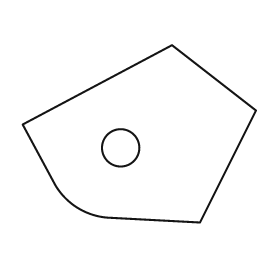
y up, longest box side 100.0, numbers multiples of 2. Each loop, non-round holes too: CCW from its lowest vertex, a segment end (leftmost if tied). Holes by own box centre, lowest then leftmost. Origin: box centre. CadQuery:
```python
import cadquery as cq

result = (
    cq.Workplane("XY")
    .moveTo(26.0, -38.0)
    .lineTo(50.0, 10.0)
    .lineTo(14.0, 38.0)
    .lineTo(-50.0, 4.0)
    .lineTo(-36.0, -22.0)
    .threePointArc((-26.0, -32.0), (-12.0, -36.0))
    .close()
    .moveTo(-8.0, -6.0)
    .circle(8.0)
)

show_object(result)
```